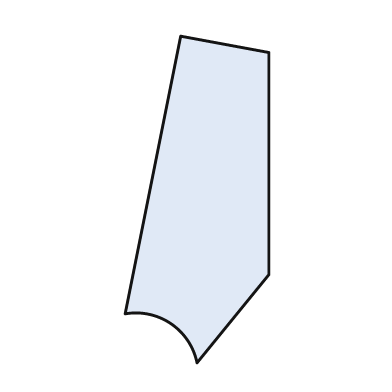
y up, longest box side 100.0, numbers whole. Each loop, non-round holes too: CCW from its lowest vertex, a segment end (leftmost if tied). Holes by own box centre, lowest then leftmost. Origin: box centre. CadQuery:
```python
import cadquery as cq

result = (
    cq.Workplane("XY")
    .moveTo(0.0, -50.0)
    .lineTo(22.0, -23.0)
    .lineTo(22.0, 45.0)
    .lineTo(-5.0, 50.0)
    .lineTo(-22.0, -35.0)
    .threePointArc((-8.0, -38.0), (0.0, -50.0))
    .close()
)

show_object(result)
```